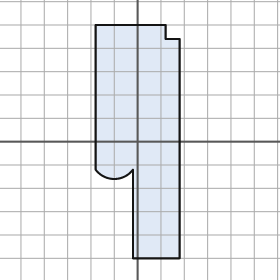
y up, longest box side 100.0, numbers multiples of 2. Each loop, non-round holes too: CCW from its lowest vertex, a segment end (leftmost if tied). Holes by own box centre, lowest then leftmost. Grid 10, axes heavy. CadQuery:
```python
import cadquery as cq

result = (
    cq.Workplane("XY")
    .moveTo(-2.0, -50.0)
    .lineTo(18.0, -50.0)
    .lineTo(18.0, 44.0)
    .lineTo(12.0, 44.0)
    .lineTo(12.0, 50.0)
    .lineTo(-18.0, 50.0)
    .lineTo(-18.0, -12.0)
    .threePointArc((-10.0, -16.0), (-2.0, -12.0))
    .close()
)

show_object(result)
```